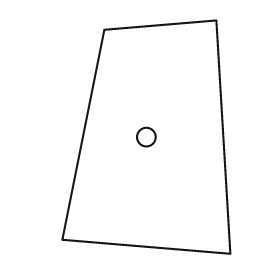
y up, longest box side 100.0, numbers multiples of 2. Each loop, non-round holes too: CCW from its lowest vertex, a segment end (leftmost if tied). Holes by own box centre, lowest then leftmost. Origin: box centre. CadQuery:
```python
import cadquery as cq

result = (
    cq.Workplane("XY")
    .moveTo(36.0, -50.0)
    .lineTo(30.0, 50.0)
    .lineTo(-18.0, 46.0)
    .lineTo(-36.0, -44.0)
    .close()
    .moveTo(0.0, 0.0)
    .circle(4.0)
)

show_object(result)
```